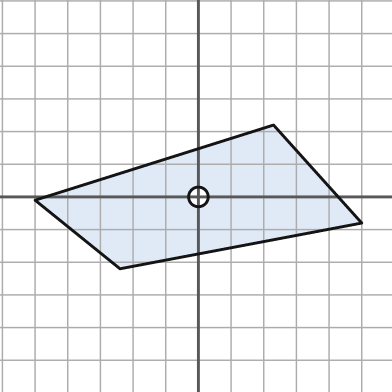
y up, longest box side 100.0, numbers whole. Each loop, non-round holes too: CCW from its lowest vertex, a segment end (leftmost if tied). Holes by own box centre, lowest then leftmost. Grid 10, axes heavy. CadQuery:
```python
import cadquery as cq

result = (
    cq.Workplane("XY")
    .moveTo(-24.0, -22.0)
    .lineTo(50.0, -8.0)
    .lineTo(23.0, 22.0)
    .lineTo(-50.0, -1.0)
    .close()
    .moveTo(0.0, 0.0)
    .circle(3.0)
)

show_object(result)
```